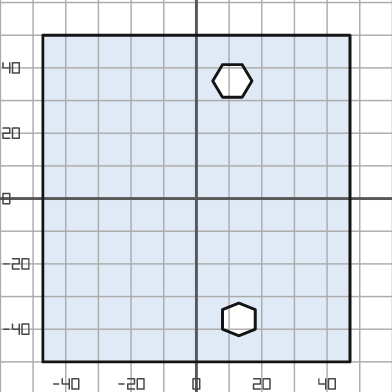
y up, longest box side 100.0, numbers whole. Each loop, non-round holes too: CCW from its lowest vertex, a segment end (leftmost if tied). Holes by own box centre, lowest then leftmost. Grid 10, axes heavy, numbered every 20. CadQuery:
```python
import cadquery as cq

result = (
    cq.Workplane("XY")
    .moveTo(-47.0, -50.0)
    .lineTo(47.0, -50.0)
    .lineTo(47.0, 50.0)
    .lineTo(-47.0, 50.0)
    .close()
    .moveTo(13.0, -42.0)
    .lineTo(18.0, -40.0)
    .lineTo(18.0, -34.0)
    .lineTo(13.0, -32.0)
    .lineTo(8.0, -34.0)
    .lineTo(8.0, -40.0)
    .close()
    .moveTo(8.0, 31.0)
    .lineTo(14.0, 31.0)
    .lineTo(17.0, 36.0)
    .lineTo(14.0, 41.0)
    .lineTo(8.0, 41.0)
    .lineTo(5.0, 36.0)
    .close()
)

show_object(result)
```